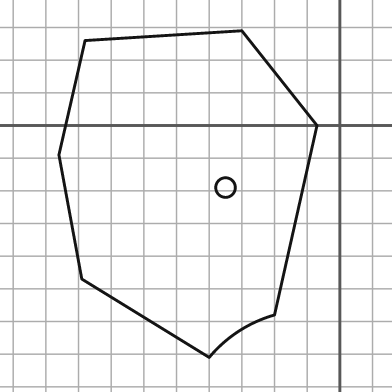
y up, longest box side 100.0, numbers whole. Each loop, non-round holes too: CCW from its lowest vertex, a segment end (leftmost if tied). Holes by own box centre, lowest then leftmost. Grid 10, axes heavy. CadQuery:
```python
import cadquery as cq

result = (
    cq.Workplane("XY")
    .moveTo(-40.0, -71.0)
    .threePointArc((-31.0, -63.0), (-20.0, -58.0))
    .lineTo(-7.0, 0.0)
    .lineTo(-30.0, 29.0)
    .lineTo(-78.0, 26.0)
    .lineTo(-86.0, -9.0)
    .lineTo(-79.0, -47.0)
    .close()
    .moveTo(-35.0, -19.0)
    .circle(3.0)
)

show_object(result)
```